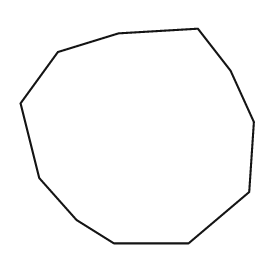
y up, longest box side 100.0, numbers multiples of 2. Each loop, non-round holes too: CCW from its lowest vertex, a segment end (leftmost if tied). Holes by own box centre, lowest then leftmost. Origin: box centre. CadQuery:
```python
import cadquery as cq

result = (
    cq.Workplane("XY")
    .moveTo(-10.0, -46.0)
    .lineTo(22.0, -46.0)
    .lineTo(48.0, -24.0)
    .lineTo(50.0, 6.0)
    .lineTo(40.0, 28.0)
    .lineTo(26.0, 46.0)
    .lineTo(-8.0, 44.0)
    .lineTo(-34.0, 36.0)
    .lineTo(-50.0, 14.0)
    .lineTo(-42.0, -18.0)
    .lineTo(-26.0, -36.0)
    .close()
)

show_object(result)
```